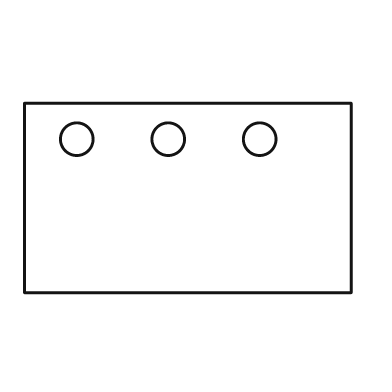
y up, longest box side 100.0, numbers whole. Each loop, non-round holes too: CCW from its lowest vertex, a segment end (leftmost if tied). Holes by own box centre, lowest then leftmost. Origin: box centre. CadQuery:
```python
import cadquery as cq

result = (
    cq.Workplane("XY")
    .moveTo(-50.0, -29.0)
    .lineTo(50.0, -29.0)
    .lineTo(50.0, 29.0)
    .lineTo(-50.0, 29.0)
    .close()
    .moveTo(-34.0, 18.0)
    .circle(5.0)
    .moveTo(-6.0, 18.0)
    .circle(5.0)
    .moveTo(22.0, 18.0)
    .circle(5.0)
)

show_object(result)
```